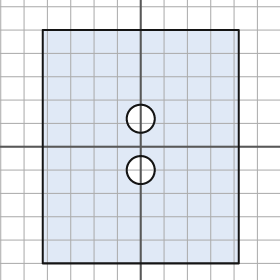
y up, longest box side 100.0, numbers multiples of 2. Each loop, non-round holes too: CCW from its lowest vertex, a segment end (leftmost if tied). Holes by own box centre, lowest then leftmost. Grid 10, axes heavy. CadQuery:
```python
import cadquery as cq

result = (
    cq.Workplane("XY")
    .moveTo(-42.0, -50.0)
    .lineTo(42.0, -50.0)
    .lineTo(42.0, 50.0)
    .lineTo(-42.0, 50.0)
    .close()
    .moveTo(0.0, -10.0)
    .circle(6.0)
    .moveTo(0.0, 12.0)
    .circle(6.0)
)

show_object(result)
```